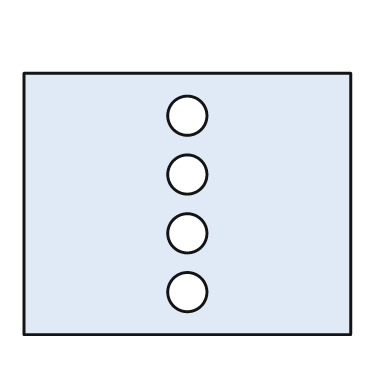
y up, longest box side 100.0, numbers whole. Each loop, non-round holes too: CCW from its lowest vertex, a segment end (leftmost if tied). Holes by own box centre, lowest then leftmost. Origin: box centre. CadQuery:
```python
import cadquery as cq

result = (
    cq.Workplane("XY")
    .moveTo(-50.0, -40.0)
    .lineTo(50.0, -40.0)
    .lineTo(50.0, 40.0)
    .lineTo(-50.0, 40.0)
    .close()
    .moveTo(0.0, -27.0)
    .circle(6.0)
    .moveTo(0.0, -9.0)
    .circle(6.0)
    .moveTo(0.0, 9.0)
    .circle(6.0)
    .moveTo(0.0, 27.0)
    .circle(6.0)
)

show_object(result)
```